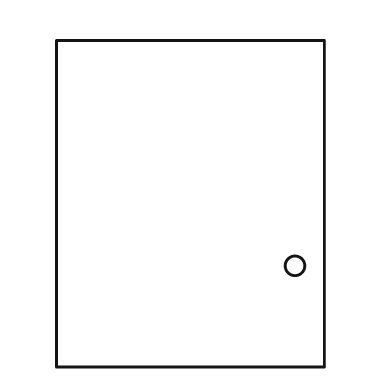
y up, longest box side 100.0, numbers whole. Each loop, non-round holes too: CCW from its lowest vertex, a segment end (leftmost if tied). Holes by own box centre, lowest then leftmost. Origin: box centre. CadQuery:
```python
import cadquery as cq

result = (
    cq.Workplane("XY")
    .moveTo(-41.0, -50.0)
    .lineTo(41.0, -50.0)
    .lineTo(41.0, 50.0)
    .lineTo(-41.0, 50.0)
    .close()
    .moveTo(32.0, -19.0)
    .circle(3.0)
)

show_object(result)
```